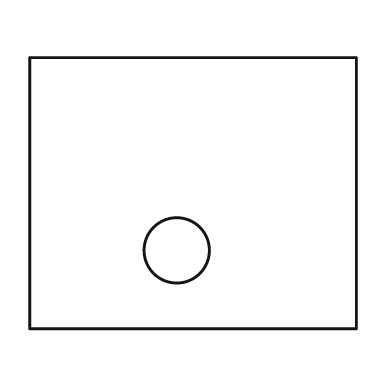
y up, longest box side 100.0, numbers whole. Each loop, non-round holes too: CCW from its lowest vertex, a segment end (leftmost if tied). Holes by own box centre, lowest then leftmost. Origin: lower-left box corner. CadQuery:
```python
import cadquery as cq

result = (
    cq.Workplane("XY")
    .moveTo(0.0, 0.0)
    .lineTo(100.0, 0.0)
    .lineTo(100.0, 83.0)
    .lineTo(0.0, 83.0)
    .close()
    .moveTo(45.0, 24.0)
    .circle(10.0)
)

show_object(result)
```